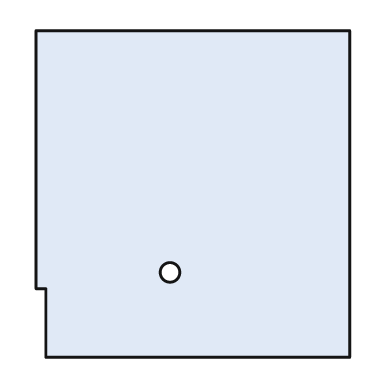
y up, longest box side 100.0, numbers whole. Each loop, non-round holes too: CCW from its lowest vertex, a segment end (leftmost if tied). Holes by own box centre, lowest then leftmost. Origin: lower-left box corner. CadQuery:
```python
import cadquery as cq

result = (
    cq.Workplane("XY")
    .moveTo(3.0, 0.0)
    .lineTo(96.0, 0.0)
    .lineTo(96.0, 100.0)
    .lineTo(0.0, 100.0)
    .lineTo(0.0, 21.0)
    .lineTo(3.0, 21.0)
    .close()
    .moveTo(41.0, 26.0)
    .circle(3.0)
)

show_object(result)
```